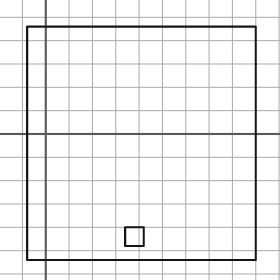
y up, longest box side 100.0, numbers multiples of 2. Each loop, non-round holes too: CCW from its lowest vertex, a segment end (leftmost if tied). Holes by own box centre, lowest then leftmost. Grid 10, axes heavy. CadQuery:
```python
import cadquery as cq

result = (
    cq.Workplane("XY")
    .moveTo(-8.0, -54.0)
    .lineTo(90.0, -54.0)
    .lineTo(90.0, 46.0)
    .lineTo(-8.0, 46.0)
    .close()
    .moveTo(34.0, -48.0)
    .lineTo(42.0, -48.0)
    .lineTo(42.0, -40.0)
    .lineTo(34.0, -40.0)
    .close()
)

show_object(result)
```